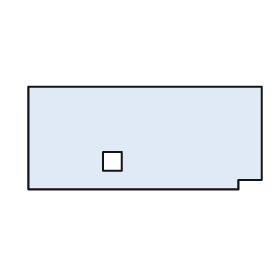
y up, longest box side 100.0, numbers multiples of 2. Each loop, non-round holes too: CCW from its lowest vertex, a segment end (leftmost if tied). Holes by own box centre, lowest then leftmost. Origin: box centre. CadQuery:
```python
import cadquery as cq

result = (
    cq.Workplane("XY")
    .moveTo(-50.0, -22.0)
    .lineTo(40.0, -22.0)
    .lineTo(40.0, -18.0)
    .lineTo(50.0, -18.0)
    .lineTo(50.0, 22.0)
    .lineTo(-50.0, 22.0)
    .close()
    .moveTo(-18.0, -14.0)
    .lineTo(-10.0, -14.0)
    .lineTo(-10.0, -6.0)
    .lineTo(-18.0, -6.0)
    .close()
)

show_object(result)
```